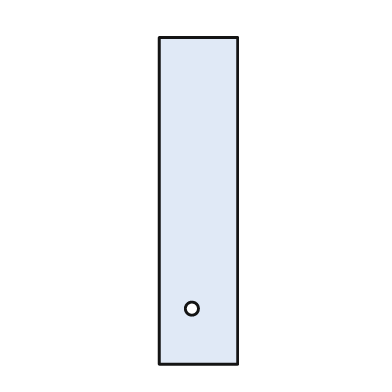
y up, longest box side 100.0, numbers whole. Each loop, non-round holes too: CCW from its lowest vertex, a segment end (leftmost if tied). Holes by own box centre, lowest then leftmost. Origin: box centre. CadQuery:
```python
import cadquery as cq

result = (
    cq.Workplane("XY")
    .moveTo(-12.0, -50.0)
    .lineTo(12.0, -50.0)
    .lineTo(12.0, 50.0)
    .lineTo(-12.0, 50.0)
    .close()
    .moveTo(-2.0, -33.0)
    .circle(2.0)
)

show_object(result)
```